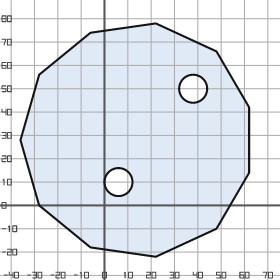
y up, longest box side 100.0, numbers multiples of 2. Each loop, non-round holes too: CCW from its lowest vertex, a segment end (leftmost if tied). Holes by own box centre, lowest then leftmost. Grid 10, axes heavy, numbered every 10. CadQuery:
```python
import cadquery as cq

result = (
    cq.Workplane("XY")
    .moveTo(22.0, -22.0)
    .lineTo(48.0, -10.0)
    .lineTo(62.0, 14.0)
    .lineTo(62.0, 42.0)
    .lineTo(48.0, 66.0)
    .lineTo(22.0, 78.0)
    .lineTo(-6.0, 74.0)
    .lineTo(-28.0, 56.0)
    .lineTo(-36.0, 28.0)
    .lineTo(-28.0, 0.0)
    .lineTo(-6.0, -18.0)
    .close()
    .moveTo(6.0, 10.0)
    .circle(6.0)
    .moveTo(38.0, 50.0)
    .circle(6.0)
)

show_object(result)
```